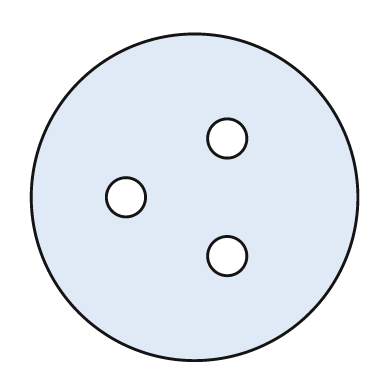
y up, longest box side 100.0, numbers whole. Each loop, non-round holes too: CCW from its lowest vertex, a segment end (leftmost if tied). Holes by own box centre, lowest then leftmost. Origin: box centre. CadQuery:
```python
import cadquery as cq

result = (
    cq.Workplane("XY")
    .moveTo(0.0, 0.0)
    .circle(50.0)
    .moveTo(10.0, -18.0)
    .circle(6.0)
    .moveTo(-21.0, 0.0)
    .circle(6.0)
    .moveTo(10.0, 18.0)
    .circle(6.0)
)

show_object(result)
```